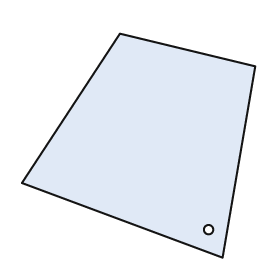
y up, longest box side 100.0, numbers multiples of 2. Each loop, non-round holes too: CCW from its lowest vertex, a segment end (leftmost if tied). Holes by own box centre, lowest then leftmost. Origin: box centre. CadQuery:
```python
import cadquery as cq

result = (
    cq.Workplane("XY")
    .moveTo(36.0, -48.0)
    .lineTo(50.0, 34.0)
    .lineTo(-8.0, 48.0)
    .lineTo(-50.0, -16.0)
    .close()
    .moveTo(30.0, -36.0)
    .circle(2.0)
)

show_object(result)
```